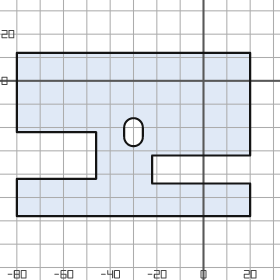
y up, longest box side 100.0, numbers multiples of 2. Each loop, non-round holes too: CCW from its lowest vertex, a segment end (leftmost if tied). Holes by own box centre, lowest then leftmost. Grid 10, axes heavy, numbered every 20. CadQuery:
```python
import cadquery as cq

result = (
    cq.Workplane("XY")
    .moveTo(-80.0, -58.0)
    .lineTo(20.0, -58.0)
    .lineTo(20.0, -44.0)
    .lineTo(-22.0, -44.0)
    .lineTo(-22.0, -32.0)
    .lineTo(20.0, -32.0)
    .lineTo(20.0, 12.0)
    .lineTo(-80.0, 12.0)
    .lineTo(-80.0, -22.0)
    .lineTo(-46.0, -22.0)
    .lineTo(-46.0, -42.0)
    .lineTo(-80.0, -42.0)
    .close()
    .moveTo(-34.0, -24.0)
    .threePointArc((-30.0, -28.0), (-26.0, -24.0))
    .lineTo(-26.0, -20.0)
    .threePointArc((-30.0, -16.0), (-34.0, -20.0))
    .close()
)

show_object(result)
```